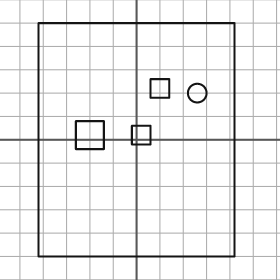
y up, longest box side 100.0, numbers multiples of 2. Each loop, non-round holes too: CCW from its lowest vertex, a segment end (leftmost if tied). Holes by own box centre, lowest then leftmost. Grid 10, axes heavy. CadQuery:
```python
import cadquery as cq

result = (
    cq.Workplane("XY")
    .moveTo(-42.0, -50.0)
    .lineTo(42.0, -50.0)
    .lineTo(42.0, 50.0)
    .lineTo(-42.0, 50.0)
    .close()
    .moveTo(-26.0, -4.0)
    .lineTo(-14.0, -4.0)
    .lineTo(-14.0, 8.0)
    .lineTo(-26.0, 8.0)
    .close()
    .moveTo(-2.0, -2.0)
    .lineTo(6.0, -2.0)
    .lineTo(6.0, 6.0)
    .lineTo(-2.0, 6.0)
    .close()
    .moveTo(26.0, 20.0)
    .circle(4.0)
    .moveTo(6.0, 18.0)
    .lineTo(14.0, 18.0)
    .lineTo(14.0, 26.0)
    .lineTo(6.0, 26.0)
    .close()
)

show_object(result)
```